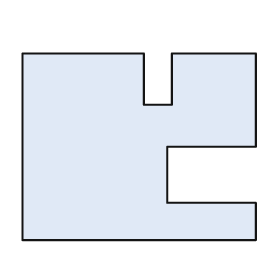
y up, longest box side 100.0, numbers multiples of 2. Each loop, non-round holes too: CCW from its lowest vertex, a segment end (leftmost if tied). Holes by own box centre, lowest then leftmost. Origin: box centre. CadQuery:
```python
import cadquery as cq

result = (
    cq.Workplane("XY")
    .moveTo(-50.0, -40.0)
    .lineTo(50.0, -40.0)
    .lineTo(50.0, -24.0)
    .lineTo(12.0, -24.0)
    .lineTo(12.0, 0.0)
    .lineTo(50.0, 0.0)
    .lineTo(50.0, 40.0)
    .lineTo(14.0, 40.0)
    .lineTo(14.0, 18.0)
    .lineTo(2.0, 18.0)
    .lineTo(2.0, 40.0)
    .lineTo(-50.0, 40.0)
    .close()
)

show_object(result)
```